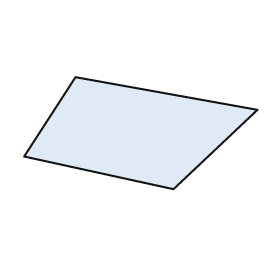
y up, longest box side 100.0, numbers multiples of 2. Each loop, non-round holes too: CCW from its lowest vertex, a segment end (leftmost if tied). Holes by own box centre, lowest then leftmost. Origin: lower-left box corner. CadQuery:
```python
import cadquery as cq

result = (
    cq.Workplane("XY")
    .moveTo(64.0, 0.0)
    .lineTo(100.0, 34.0)
    .lineTo(22.0, 48.0)
    .lineTo(0.0, 14.0)
    .close()
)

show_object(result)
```